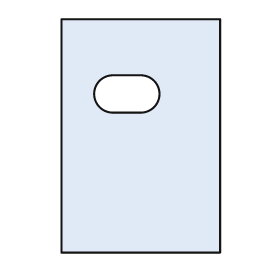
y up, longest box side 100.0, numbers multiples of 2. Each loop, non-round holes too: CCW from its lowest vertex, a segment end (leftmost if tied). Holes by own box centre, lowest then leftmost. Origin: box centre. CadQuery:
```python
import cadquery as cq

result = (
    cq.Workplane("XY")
    .moveTo(-34.0, -50.0)
    .lineTo(34.0, -50.0)
    .lineTo(34.0, 50.0)
    .lineTo(-34.0, 50.0)
    .close()
    .moveTo(-12.0, 10.0)
    .lineTo(0.0, 10.0)
    .threePointArc((8.0, 18.0), (0.0, 26.0))
    .lineTo(-12.0, 26.0)
    .threePointArc((-20.0, 18.0), (-12.0, 10.0))
    .close()
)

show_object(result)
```